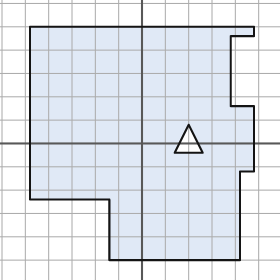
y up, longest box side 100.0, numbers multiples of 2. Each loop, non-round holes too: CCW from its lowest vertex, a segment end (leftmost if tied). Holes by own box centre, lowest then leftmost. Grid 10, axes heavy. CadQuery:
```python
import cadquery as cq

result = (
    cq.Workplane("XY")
    .moveTo(-14.0, -50.0)
    .lineTo(42.0, -50.0)
    .lineTo(42.0, -12.0)
    .lineTo(48.0, -12.0)
    .lineTo(48.0, 16.0)
    .lineTo(38.0, 16.0)
    .lineTo(38.0, 46.0)
    .lineTo(48.0, 46.0)
    .lineTo(48.0, 50.0)
    .lineTo(-48.0, 50.0)
    .lineTo(-48.0, -24.0)
    .lineTo(-14.0, -24.0)
    .close()
    .moveTo(14.0, -4.0)
    .lineTo(26.0, -4.0)
    .lineTo(20.0, 8.0)
    .close()
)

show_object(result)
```